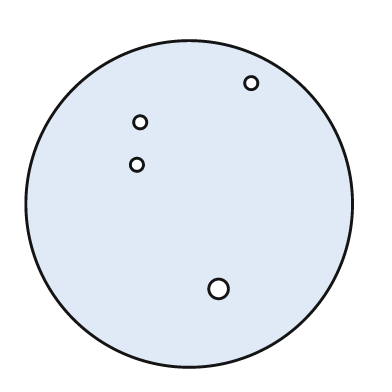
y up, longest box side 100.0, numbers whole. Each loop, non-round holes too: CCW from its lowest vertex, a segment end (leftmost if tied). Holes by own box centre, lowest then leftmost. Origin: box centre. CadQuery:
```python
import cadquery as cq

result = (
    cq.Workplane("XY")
    .moveTo(0.0, 0.0)
    .circle(50.0)
    .moveTo(9.0, -26.0)
    .circle(3.0)
    .moveTo(-16.0, 12.0)
    .circle(2.0)
    .moveTo(-15.0, 25.0)
    .circle(2.0)
    .moveTo(19.0, 37.0)
    .circle(2.0)
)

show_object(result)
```